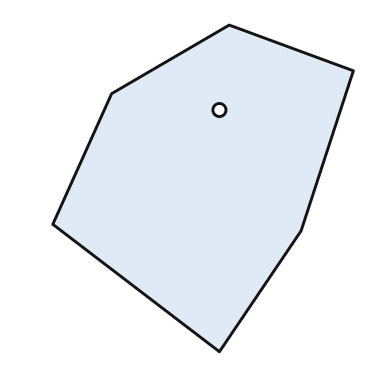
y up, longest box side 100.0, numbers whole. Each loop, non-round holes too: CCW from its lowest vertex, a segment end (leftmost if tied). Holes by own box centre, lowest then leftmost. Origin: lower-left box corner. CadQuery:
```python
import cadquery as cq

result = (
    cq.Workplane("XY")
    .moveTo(51.0, 0.0)
    .lineTo(76.0, 37.0)
    .lineTo(92.0, 86.0)
    .lineTo(54.0, 100.0)
    .lineTo(18.0, 79.0)
    .lineTo(0.0, 39.0)
    .close()
    .moveTo(51.0, 74.0)
    .circle(2.0)
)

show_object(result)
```